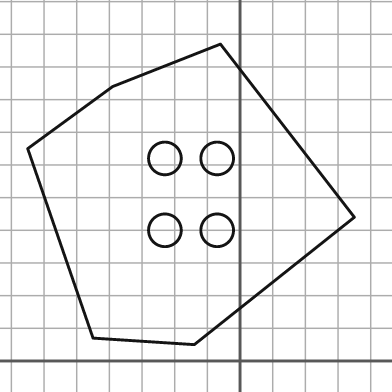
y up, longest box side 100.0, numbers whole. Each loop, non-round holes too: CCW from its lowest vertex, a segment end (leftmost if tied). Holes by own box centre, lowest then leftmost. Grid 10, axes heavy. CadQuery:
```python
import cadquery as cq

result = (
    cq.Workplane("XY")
    .moveTo(-14.0, 5.0)
    .lineTo(35.0, 44.0)
    .lineTo(-6.0, 97.0)
    .lineTo(-39.0, 84.0)
    .lineTo(-65.0, 65.0)
    .lineTo(-45.0, 7.0)
    .close()
    .moveTo(-23.0, 40.0)
    .circle(5.0)
    .moveTo(-7.0, 40.0)
    .circle(5.0)
    .moveTo(-23.0, 62.0)
    .circle(5.0)
    .moveTo(-7.0, 62.0)
    .circle(5.0)
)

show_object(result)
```